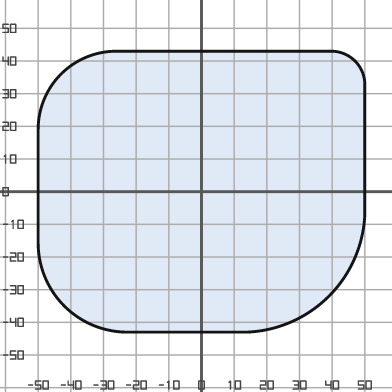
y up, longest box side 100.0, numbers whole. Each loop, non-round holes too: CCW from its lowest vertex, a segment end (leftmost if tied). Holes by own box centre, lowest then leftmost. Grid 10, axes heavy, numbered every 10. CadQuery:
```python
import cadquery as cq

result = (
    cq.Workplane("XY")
    .moveTo(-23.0, -43.0)
    .lineTo(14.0, -43.0)
    .threePointArc((39.0, -32.0), (50.0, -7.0))
    .lineTo(50.0, 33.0)
    .threePointArc((47.0, 40.0), (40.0, 43.0))
    .lineTo(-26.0, 43.0)
    .threePointArc((-43.0, 36.0), (-50.0, 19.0))
    .lineTo(-50.0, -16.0)
    .threePointArc((-42.0, -35.0), (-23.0, -43.0))
    .close()
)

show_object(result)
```